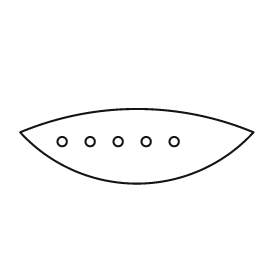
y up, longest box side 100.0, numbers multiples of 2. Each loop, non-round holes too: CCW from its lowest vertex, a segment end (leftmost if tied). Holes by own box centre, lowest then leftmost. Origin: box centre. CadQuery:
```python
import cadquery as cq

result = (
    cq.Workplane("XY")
    .moveTo(-50.0, 6.0)
    .threePointArc((0.0, -16.0), (50.0, 6.0))
    .threePointArc((0.0, 16.0), (-50.0, 6.0))
    .close()
    .moveTo(-32.0, 2.0)
    .circle(2.0)
    .moveTo(-20.0, 2.0)
    .circle(2.0)
    .moveTo(-8.0, 2.0)
    .circle(2.0)
    .moveTo(4.0, 2.0)
    .circle(2.0)
    .moveTo(16.0, 2.0)
    .circle(2.0)
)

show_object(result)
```